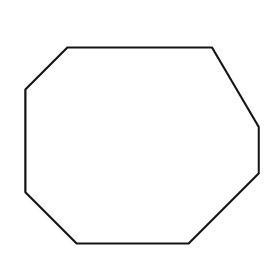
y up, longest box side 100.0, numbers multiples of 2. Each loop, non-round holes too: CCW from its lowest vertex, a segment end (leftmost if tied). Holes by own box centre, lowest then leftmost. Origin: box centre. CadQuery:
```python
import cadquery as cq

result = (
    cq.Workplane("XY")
    .moveTo(-28.0, -42.0)
    .lineTo(20.0, -42.0)
    .lineTo(50.0, -12.0)
    .lineTo(50.0, 8.0)
    .lineTo(30.0, 42.0)
    .lineTo(-32.0, 42.0)
    .lineTo(-50.0, 24.0)
    .lineTo(-50.0, -20.0)
    .close()
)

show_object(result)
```